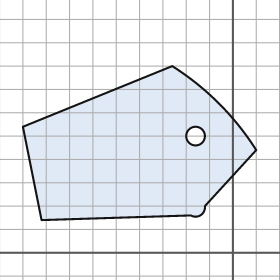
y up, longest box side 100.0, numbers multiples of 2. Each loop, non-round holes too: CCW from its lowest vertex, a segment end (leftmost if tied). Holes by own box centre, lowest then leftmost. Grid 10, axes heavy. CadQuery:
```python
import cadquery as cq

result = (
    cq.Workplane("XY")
    .moveTo(-82.0, 14.0)
    .lineTo(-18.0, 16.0)
    .threePointArc((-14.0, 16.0), (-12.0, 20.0))
    .lineTo(10.0, 44.0)
    .threePointArc((-6.0, 64.0), (-26.0, 80.0))
    .lineTo(-90.0, 54.0)
    .close()
    .moveTo(-16.0, 50.0)
    .circle(4.0)
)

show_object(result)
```